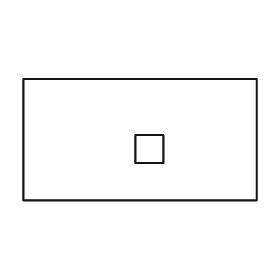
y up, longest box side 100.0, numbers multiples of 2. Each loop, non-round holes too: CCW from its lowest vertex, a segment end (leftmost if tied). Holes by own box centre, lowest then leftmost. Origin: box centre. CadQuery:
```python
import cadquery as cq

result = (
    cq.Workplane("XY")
    .moveTo(-50.0, -26.0)
    .lineTo(50.0, -26.0)
    .lineTo(50.0, 26.0)
    .lineTo(-50.0, 26.0)
    .close()
    .moveTo(-2.0, -10.0)
    .lineTo(10.0, -10.0)
    .lineTo(10.0, 2.0)
    .lineTo(-2.0, 2.0)
    .close()
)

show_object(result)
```